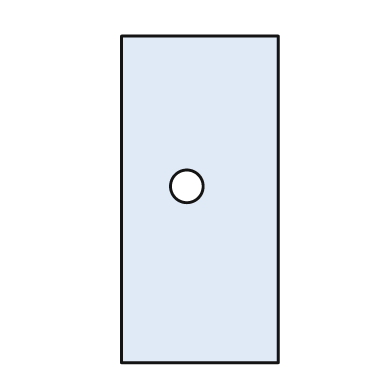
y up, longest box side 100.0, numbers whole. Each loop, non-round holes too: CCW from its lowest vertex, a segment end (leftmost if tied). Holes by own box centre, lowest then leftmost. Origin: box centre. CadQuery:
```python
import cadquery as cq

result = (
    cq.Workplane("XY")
    .moveTo(-24.0, -50.0)
    .lineTo(24.0, -50.0)
    .lineTo(24.0, 50.0)
    .lineTo(-24.0, 50.0)
    .close()
    .moveTo(-4.0, 4.0)
    .circle(5.0)
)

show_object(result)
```